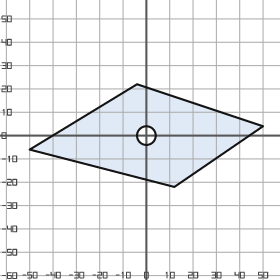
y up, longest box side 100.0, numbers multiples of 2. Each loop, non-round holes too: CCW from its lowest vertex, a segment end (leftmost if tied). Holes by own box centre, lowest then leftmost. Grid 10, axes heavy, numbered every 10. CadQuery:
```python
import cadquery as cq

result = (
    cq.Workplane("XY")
    .moveTo(12.0, -22.0)
    .lineTo(50.0, 4.0)
    .lineTo(-4.0, 22.0)
    .lineTo(-50.0, -6.0)
    .close()
    .moveTo(0.0, 0.0)
    .circle(4.0)
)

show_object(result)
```